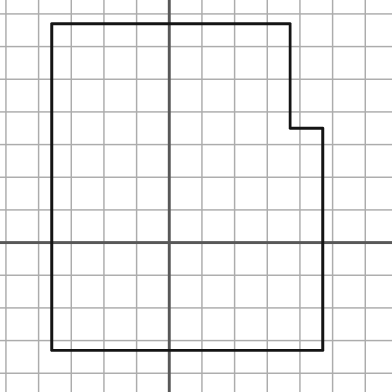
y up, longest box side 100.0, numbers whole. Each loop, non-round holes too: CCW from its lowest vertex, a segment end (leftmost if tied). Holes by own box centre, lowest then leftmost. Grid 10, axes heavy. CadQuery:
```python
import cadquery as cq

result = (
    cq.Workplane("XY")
    .moveTo(-36.0, -33.0)
    .lineTo(47.0, -33.0)
    .lineTo(47.0, 35.0)
    .lineTo(37.0, 35.0)
    .lineTo(37.0, 67.0)
    .lineTo(-36.0, 67.0)
    .close()
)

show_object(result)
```